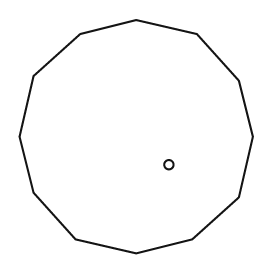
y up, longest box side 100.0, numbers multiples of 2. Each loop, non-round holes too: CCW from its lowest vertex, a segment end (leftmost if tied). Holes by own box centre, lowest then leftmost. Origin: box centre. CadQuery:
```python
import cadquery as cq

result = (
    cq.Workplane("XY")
    .moveTo(0.0, -50.0)
    .lineTo(24.0, -44.0)
    .lineTo(44.0, -26.0)
    .lineTo(50.0, 0.0)
    .lineTo(44.0, 24.0)
    .lineTo(26.0, 44.0)
    .lineTo(0.0, 50.0)
    .lineTo(-24.0, 44.0)
    .lineTo(-44.0, 26.0)
    .lineTo(-50.0, 0.0)
    .lineTo(-44.0, -24.0)
    .lineTo(-26.0, -44.0)
    .close()
    .moveTo(14.0, -12.0)
    .circle(2.0)
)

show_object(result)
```